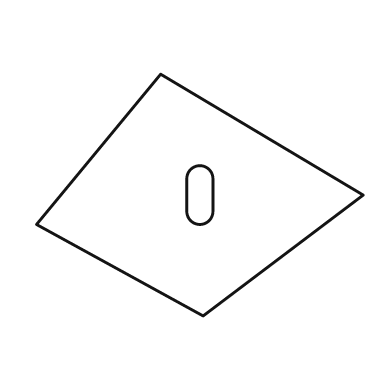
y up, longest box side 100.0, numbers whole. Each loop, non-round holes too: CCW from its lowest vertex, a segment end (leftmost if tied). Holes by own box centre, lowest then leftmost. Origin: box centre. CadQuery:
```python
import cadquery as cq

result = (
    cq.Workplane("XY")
    .moveTo(1.0, -37.0)
    .lineTo(50.0, 0.0)
    .lineTo(-12.0, 37.0)
    .lineTo(-50.0, -9.0)
    .close()
    .moveTo(-4.0, -5.0)
    .threePointArc((0.0, -9.0), (4.0, -5.0))
    .lineTo(4.0, 5.0)
    .threePointArc((0.0, 9.0), (-4.0, 5.0))
    .close()
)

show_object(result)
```